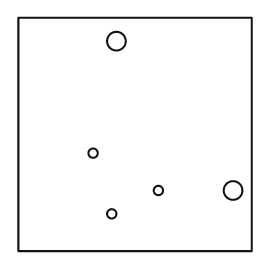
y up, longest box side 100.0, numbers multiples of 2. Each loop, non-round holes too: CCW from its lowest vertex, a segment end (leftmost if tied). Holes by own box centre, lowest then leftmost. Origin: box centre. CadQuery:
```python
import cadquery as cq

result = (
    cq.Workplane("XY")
    .moveTo(-50.0, -50.0)
    .lineTo(50.0, -50.0)
    .lineTo(50.0, 50.0)
    .lineTo(-50.0, 50.0)
    .close()
    .moveTo(-10.0, -34.0)
    .circle(2.0)
    .moveTo(10.0, -24.0)
    .circle(2.0)
    .moveTo(42.0, -24.0)
    .circle(4.0)
    .moveTo(-18.0, -8.0)
    .circle(2.0)
    .moveTo(-8.0, 40.0)
    .circle(4.0)
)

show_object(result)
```